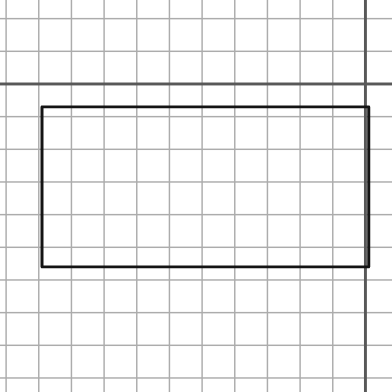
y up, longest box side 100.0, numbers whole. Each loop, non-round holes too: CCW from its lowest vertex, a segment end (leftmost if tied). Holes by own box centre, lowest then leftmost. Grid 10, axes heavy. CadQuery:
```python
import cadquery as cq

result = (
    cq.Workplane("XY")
    .moveTo(-99.0, -56.0)
    .lineTo(1.0, -56.0)
    .lineTo(1.0, -7.0)
    .lineTo(-99.0, -7.0)
    .close()
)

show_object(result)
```